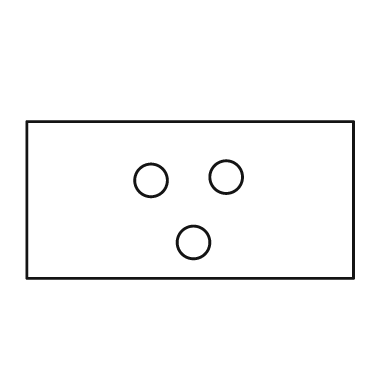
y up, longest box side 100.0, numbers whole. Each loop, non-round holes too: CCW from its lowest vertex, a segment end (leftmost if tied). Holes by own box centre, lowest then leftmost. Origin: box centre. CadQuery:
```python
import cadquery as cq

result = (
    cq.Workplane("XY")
    .moveTo(-50.0, -24.0)
    .lineTo(50.0, -24.0)
    .lineTo(50.0, 24.0)
    .lineTo(-50.0, 24.0)
    .close()
    .moveTo(1.0, -13.0)
    .circle(5.0)
    .moveTo(-12.0, 6.0)
    .circle(5.0)
    .moveTo(11.0, 7.0)
    .circle(5.0)
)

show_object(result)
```